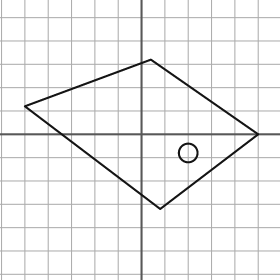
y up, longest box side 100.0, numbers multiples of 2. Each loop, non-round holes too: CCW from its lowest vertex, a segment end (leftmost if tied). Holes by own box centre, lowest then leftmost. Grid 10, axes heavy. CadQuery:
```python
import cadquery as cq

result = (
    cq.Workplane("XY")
    .moveTo(8.0, -32.0)
    .lineTo(50.0, 0.0)
    .lineTo(4.0, 32.0)
    .lineTo(-50.0, 12.0)
    .close()
    .moveTo(20.0, -8.0)
    .circle(4.0)
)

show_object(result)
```